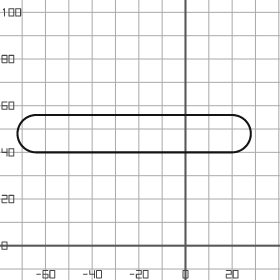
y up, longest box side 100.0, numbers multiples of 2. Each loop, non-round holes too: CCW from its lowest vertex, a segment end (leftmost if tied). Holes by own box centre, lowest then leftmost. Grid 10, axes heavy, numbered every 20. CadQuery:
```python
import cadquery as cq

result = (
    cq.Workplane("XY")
    .moveTo(-64.0, 40.0)
    .lineTo(20.0, 40.0)
    .threePointArc((28.0, 48.0), (20.0, 56.0))
    .lineTo(-64.0, 56.0)
    .threePointArc((-72.0, 48.0), (-64.0, 40.0))
    .close()
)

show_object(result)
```